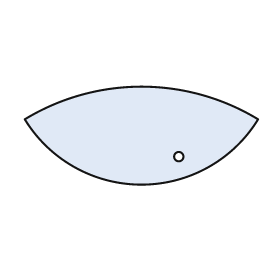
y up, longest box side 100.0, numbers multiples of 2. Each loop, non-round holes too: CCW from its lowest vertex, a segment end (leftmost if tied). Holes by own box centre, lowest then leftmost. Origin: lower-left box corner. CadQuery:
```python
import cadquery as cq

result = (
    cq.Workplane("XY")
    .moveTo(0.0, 28.0)
    .threePointArc((50.0, 0.0), (100.0, 28.0))
    .threePointArc((50.0, 42.0), (0.0, 28.0))
    .close()
    .moveTo(66.0, 12.0)
    .circle(2.0)
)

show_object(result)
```